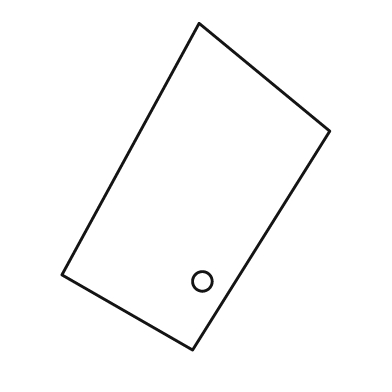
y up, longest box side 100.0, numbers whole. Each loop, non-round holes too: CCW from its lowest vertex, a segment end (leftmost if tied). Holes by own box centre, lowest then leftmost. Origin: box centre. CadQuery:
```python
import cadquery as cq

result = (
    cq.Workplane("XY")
    .moveTo(-1.0, -50.0)
    .lineTo(41.0, 17.0)
    .lineTo(1.0, 50.0)
    .lineTo(-41.0, -27.0)
    .close()
    .moveTo(2.0, -29.0)
    .circle(3.0)
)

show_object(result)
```